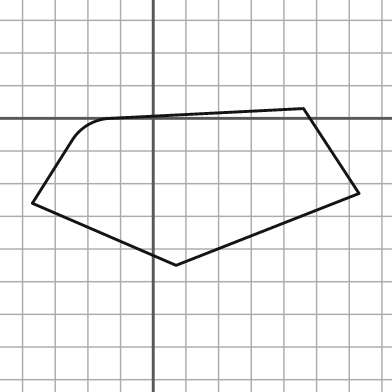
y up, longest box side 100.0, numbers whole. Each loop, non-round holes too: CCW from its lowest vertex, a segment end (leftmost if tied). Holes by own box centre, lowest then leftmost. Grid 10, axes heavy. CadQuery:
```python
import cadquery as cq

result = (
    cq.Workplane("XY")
    .moveTo(7.0, -45.0)
    .lineTo(63.0, -23.0)
    .lineTo(46.0, 3.0)
    .lineTo(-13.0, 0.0)
    .threePointArc((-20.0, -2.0), (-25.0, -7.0))
    .lineTo(-37.0, -26.0)
    .close()
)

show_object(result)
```